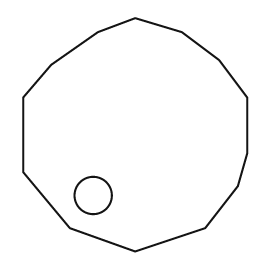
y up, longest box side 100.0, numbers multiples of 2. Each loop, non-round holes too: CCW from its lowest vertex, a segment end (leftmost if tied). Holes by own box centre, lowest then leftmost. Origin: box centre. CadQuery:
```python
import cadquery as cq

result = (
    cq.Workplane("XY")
    .moveTo(0.0, -50.0)
    .lineTo(30.0, -40.0)
    .lineTo(44.0, -22.0)
    .lineTo(48.0, -8.0)
    .lineTo(48.0, 16.0)
    .lineTo(36.0, 32.0)
    .lineTo(20.0, 44.0)
    .lineTo(0.0, 50.0)
    .lineTo(-16.0, 44.0)
    .lineTo(-36.0, 30.0)
    .lineTo(-48.0, 16.0)
    .lineTo(-48.0, -16.0)
    .lineTo(-28.0, -40.0)
    .close()
    .moveTo(-18.0, -26.0)
    .circle(8.0)
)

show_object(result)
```